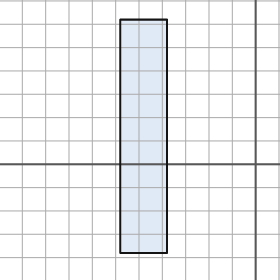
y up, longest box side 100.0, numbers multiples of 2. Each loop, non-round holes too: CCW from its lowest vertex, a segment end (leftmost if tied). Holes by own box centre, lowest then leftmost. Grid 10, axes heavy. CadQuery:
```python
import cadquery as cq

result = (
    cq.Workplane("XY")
    .moveTo(-58.0, -38.0)
    .lineTo(-38.0, -38.0)
    .lineTo(-38.0, 62.0)
    .lineTo(-58.0, 62.0)
    .close()
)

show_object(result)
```